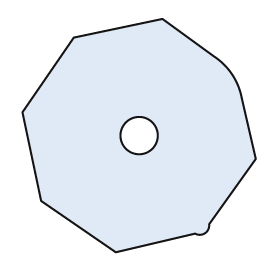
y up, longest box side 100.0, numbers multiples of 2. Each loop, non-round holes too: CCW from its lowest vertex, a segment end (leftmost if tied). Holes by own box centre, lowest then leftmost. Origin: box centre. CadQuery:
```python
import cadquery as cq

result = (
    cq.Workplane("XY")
    .moveTo(-10.0, -50.0)
    .lineTo(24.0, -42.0)
    .threePointArc((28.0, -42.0), (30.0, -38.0))
    .lineTo(50.0, -10.0)
    .lineTo(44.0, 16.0)
    .threePointArc((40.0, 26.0), (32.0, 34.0))
    .lineTo(10.0, 50.0)
    .lineTo(-28.0, 42.0)
    .lineTo(-50.0, 10.0)
    .lineTo(-42.0, -28.0)
    .close()
    .moveTo(0.0, 0.0)
    .circle(8.0)
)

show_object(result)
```